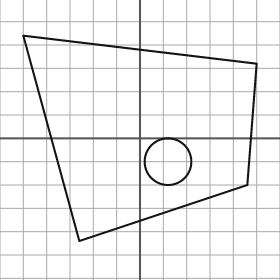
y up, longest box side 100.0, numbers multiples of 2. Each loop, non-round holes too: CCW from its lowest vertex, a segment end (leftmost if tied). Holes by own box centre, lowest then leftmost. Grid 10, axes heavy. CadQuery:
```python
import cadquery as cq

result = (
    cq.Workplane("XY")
    .moveTo(-26.0, -44.0)
    .lineTo(46.0, -20.0)
    .lineTo(50.0, 32.0)
    .lineTo(-50.0, 44.0)
    .close()
    .moveTo(12.0, -10.0)
    .circle(10.0)
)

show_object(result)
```